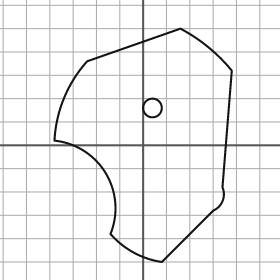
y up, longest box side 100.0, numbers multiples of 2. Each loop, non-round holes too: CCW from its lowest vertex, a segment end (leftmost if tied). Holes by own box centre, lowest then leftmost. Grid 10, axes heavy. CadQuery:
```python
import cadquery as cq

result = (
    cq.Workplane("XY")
    .moveTo(8.0, -50.0)
    .lineTo(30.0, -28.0)
    .threePointArc((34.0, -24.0), (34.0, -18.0))
    .lineTo(38.0, 32.0)
    .threePointArc((28.0, 42.0), (16.0, 50.0))
    .lineTo(-24.0, 36.0)
    .threePointArc((-34.0, 20.0), (-38.0, 2.0))
    .threePointArc((-16.0, -12.0), (-14.0, -38.0))
    .threePointArc((-4.0, -46.0), (8.0, -50.0))
    .close()
    .moveTo(4.0, 16.0)
    .circle(4.0)
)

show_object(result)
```